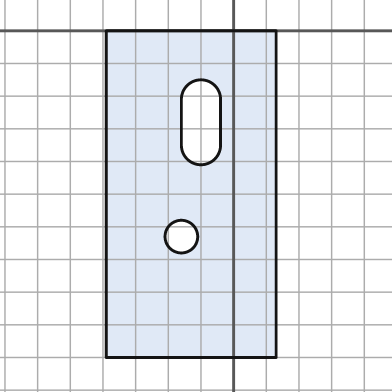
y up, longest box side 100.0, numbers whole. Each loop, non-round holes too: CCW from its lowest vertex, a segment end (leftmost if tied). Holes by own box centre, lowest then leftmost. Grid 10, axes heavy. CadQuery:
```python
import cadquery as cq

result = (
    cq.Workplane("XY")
    .moveTo(-39.0, -100.0)
    .lineTo(13.0, -100.0)
    .lineTo(13.0, 0.0)
    .lineTo(-39.0, 0.0)
    .close()
    .moveTo(-16.0, -63.0)
    .circle(5.0)
    .moveTo(-16.0, -35.0)
    .threePointArc((-10.0, -41.0), (-4.0, -35.0))
    .lineTo(-4.0, -21.0)
    .threePointArc((-10.0, -15.0), (-16.0, -21.0))
    .close()
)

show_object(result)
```